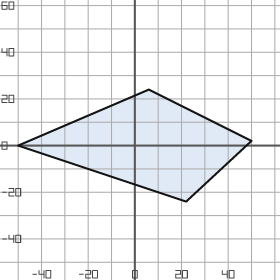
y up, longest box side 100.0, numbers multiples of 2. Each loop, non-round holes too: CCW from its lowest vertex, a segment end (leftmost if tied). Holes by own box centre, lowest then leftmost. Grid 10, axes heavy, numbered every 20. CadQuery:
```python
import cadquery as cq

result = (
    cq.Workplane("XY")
    .moveTo(22.0, -24.0)
    .lineTo(50.0, 2.0)
    .lineTo(6.0, 24.0)
    .lineTo(-50.0, 0.0)
    .close()
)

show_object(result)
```